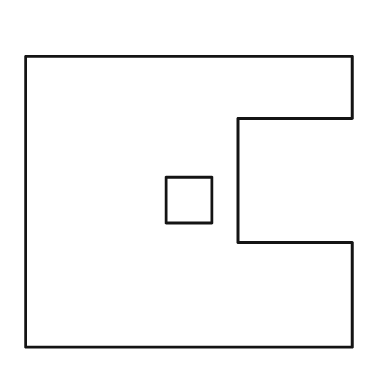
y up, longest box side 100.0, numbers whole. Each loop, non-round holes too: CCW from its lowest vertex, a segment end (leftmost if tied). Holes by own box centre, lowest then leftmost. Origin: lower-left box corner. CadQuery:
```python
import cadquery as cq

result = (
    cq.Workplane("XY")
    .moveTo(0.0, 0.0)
    .lineTo(100.0, 0.0)
    .lineTo(100.0, 32.0)
    .lineTo(65.0, 32.0)
    .lineTo(65.0, 70.0)
    .lineTo(100.0, 70.0)
    .lineTo(100.0, 89.0)
    .lineTo(0.0, 89.0)
    .close()
    .moveTo(43.0, 38.0)
    .lineTo(57.0, 38.0)
    .lineTo(57.0, 52.0)
    .lineTo(43.0, 52.0)
    .close()
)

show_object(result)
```